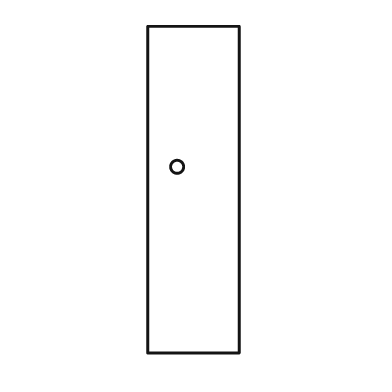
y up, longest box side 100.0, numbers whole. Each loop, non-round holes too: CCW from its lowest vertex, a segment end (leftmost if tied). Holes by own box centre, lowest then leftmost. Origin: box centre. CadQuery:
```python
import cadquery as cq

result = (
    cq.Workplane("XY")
    .moveTo(-14.0, -50.0)
    .lineTo(14.0, -50.0)
    .lineTo(14.0, 50.0)
    .lineTo(-14.0, 50.0)
    .close()
    .moveTo(-5.0, 7.0)
    .circle(2.0)
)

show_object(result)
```